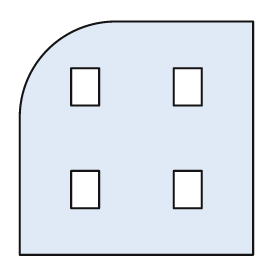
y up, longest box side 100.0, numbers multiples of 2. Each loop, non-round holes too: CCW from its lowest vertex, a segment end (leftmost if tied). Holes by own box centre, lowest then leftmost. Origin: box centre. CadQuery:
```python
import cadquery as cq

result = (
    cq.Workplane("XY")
    .moveTo(-50.0, -50.0)
    .lineTo(50.0, -50.0)
    .lineTo(50.0, 50.0)
    .lineTo(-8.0, 50.0)
    .threePointArc((-38.0, 38.0), (-50.0, 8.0))
    .close()
    .moveTo(-28.0, -30.0)
    .lineTo(-16.0, -30.0)
    .lineTo(-16.0, -14.0)
    .lineTo(-28.0, -14.0)
    .close()
    .moveTo(16.0, -30.0)
    .lineTo(28.0, -30.0)
    .lineTo(28.0, -14.0)
    .lineTo(16.0, -14.0)
    .close()
    .moveTo(-28.0, 14.0)
    .lineTo(-16.0, 14.0)
    .lineTo(-16.0, 30.0)
    .lineTo(-28.0, 30.0)
    .close()
    .moveTo(16.0, 14.0)
    .lineTo(28.0, 14.0)
    .lineTo(28.0, 30.0)
    .lineTo(16.0, 30.0)
    .close()
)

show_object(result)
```